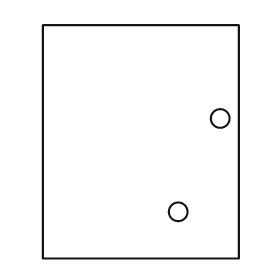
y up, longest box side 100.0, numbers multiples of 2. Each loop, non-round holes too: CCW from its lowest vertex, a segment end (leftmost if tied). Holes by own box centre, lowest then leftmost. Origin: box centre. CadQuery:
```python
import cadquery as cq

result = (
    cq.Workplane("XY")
    .moveTo(-42.0, -50.0)
    .lineTo(42.0, -50.0)
    .lineTo(42.0, 50.0)
    .lineTo(-42.0, 50.0)
    .close()
    .moveTo(16.0, -30.0)
    .circle(4.0)
    .moveTo(34.0, 10.0)
    .circle(4.0)
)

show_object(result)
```